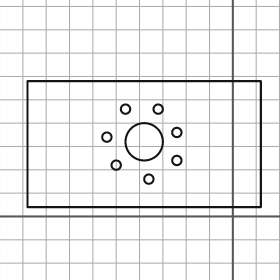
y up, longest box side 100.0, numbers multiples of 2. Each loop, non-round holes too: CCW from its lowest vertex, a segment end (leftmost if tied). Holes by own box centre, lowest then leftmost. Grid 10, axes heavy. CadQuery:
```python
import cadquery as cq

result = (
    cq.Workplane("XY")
    .moveTo(-88.0, 4.0)
    .lineTo(12.0, 4.0)
    .lineTo(12.0, 58.0)
    .lineTo(-88.0, 58.0)
    .close()
    .moveTo(-36.0, 16.0)
    .circle(2.0)
    .moveTo(-50.0, 22.0)
    .circle(2.0)
    .moveTo(-24.0, 24.0)
    .circle(2.0)
    .moveTo(-38.0, 32.0)
    .circle(8.0)
    .moveTo(-54.0, 34.0)
    .circle(2.0)
    .moveTo(-24.0, 36.0)
    .circle(2.0)
    .moveTo(-46.0, 46.0)
    .circle(2.0)
    .moveTo(-32.0, 46.0)
    .circle(2.0)
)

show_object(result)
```